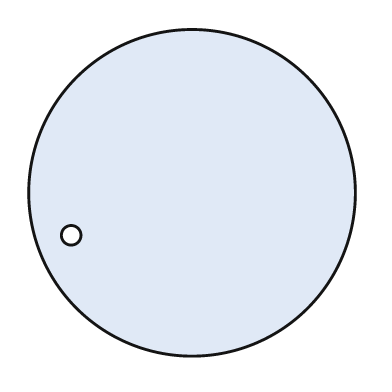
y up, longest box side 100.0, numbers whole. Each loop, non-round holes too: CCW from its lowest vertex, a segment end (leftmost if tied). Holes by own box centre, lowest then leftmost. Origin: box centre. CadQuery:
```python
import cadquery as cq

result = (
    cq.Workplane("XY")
    .moveTo(0.0, 0.0)
    .circle(50.0)
    .moveTo(-37.0, -13.0)
    .circle(3.0)
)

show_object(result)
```